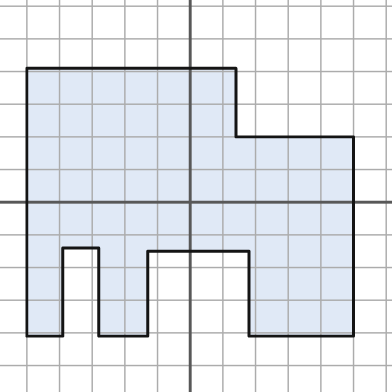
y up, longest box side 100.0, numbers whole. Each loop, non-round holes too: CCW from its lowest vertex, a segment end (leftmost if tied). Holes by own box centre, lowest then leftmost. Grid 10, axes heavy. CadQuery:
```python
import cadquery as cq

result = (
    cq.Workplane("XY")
    .moveTo(-50.0, -41.0)
    .lineTo(-39.0, -41.0)
    .lineTo(-39.0, -14.0)
    .lineTo(-28.0, -14.0)
    .lineTo(-28.0, -41.0)
    .lineTo(-13.0, -41.0)
    .lineTo(-13.0, -15.0)
    .lineTo(18.0, -15.0)
    .lineTo(18.0, -41.0)
    .lineTo(50.0, -41.0)
    .lineTo(50.0, 20.0)
    .lineTo(14.0, 20.0)
    .lineTo(14.0, 41.0)
    .lineTo(-50.0, 41.0)
    .close()
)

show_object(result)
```